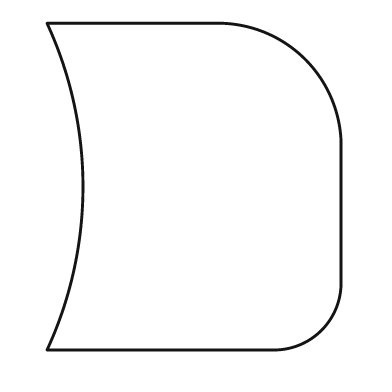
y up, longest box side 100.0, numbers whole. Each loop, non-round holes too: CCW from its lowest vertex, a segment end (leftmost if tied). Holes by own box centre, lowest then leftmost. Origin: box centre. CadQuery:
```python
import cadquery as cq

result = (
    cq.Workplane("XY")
    .moveTo(-45.0, -50.0)
    .lineTo(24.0, -50.0)
    .threePointArc((39.0, -44.0), (45.0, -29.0))
    .lineTo(45.0, 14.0)
    .threePointArc((34.0, 39.0), (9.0, 50.0))
    .lineTo(-45.0, 50.0)
    .threePointArc((-34.0, 0.0), (-45.0, -50.0))
    .close()
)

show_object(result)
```